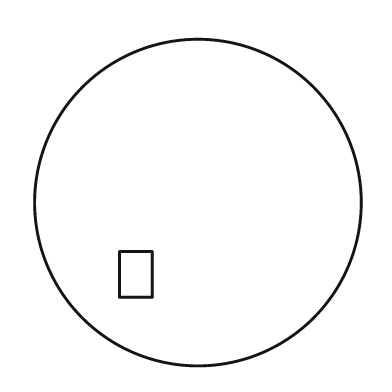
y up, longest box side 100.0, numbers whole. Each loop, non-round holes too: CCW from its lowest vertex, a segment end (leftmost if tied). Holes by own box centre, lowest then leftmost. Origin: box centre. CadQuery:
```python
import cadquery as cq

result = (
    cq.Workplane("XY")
    .moveTo(0.0, 0.0)
    .circle(50.0)
    .moveTo(-24.0, -29.0)
    .lineTo(-14.0, -29.0)
    .lineTo(-14.0, -15.0)
    .lineTo(-24.0, -15.0)
    .close()
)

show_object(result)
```